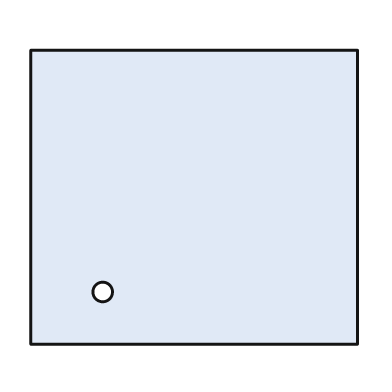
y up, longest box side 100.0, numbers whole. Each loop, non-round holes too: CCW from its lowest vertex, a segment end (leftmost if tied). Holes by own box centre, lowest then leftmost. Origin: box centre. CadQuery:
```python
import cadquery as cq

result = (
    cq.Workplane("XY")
    .moveTo(-50.0, -45.0)
    .lineTo(50.0, -45.0)
    .lineTo(50.0, 45.0)
    .lineTo(-50.0, 45.0)
    .close()
    .moveTo(-28.0, -29.0)
    .circle(3.0)
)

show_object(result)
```